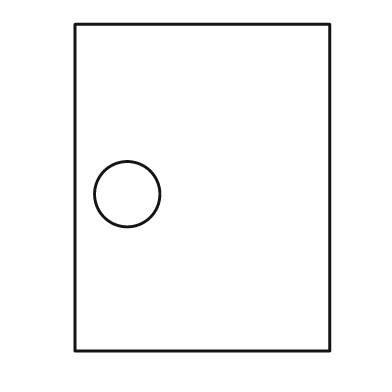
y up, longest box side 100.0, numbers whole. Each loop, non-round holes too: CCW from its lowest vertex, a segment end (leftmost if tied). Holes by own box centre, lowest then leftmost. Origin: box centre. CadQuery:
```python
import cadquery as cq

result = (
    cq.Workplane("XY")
    .moveTo(-39.0, -50.0)
    .lineTo(39.0, -50.0)
    .lineTo(39.0, 50.0)
    .lineTo(-39.0, 50.0)
    .close()
    .moveTo(-23.0, -2.0)
    .circle(10.0)
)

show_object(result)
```